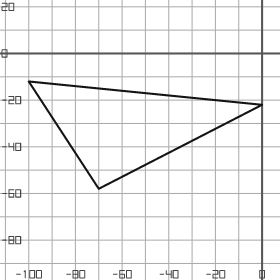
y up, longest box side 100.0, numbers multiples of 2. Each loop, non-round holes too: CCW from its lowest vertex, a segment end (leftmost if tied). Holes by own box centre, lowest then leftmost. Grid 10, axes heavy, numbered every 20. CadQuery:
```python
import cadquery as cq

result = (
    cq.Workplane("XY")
    .moveTo(-70.0, -58.0)
    .lineTo(0.0, -22.0)
    .lineTo(-100.0, -12.0)
    .close()
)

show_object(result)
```